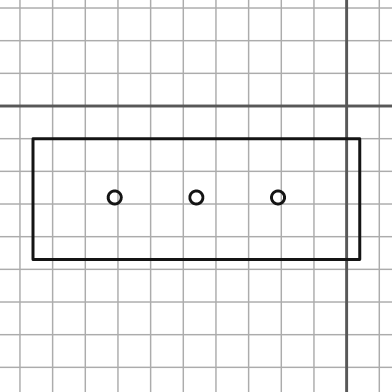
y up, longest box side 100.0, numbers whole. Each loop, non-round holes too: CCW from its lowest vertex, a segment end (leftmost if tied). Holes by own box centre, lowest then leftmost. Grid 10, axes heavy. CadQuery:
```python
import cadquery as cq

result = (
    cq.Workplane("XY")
    .moveTo(-96.0, -47.0)
    .lineTo(4.0, -47.0)
    .lineTo(4.0, -10.0)
    .lineTo(-96.0, -10.0)
    .close()
    .moveTo(-71.0, -28.0)
    .circle(2.0)
    .moveTo(-46.0, -28.0)
    .circle(2.0)
    .moveTo(-21.0, -28.0)
    .circle(2.0)
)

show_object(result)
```